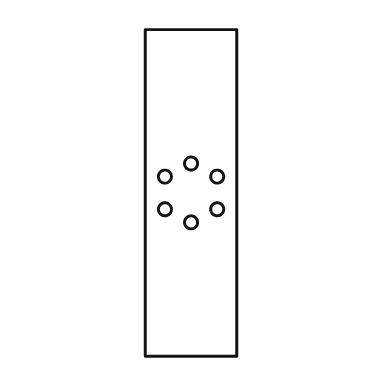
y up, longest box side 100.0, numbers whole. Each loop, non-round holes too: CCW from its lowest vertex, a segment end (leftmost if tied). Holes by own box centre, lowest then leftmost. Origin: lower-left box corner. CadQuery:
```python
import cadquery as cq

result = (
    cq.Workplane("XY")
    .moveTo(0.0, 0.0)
    .lineTo(28.0, 0.0)
    .lineTo(28.0, 100.0)
    .lineTo(0.0, 100.0)
    .close()
    .moveTo(14.0, 41.0)
    .circle(2.0)
    .moveTo(6.0, 45.0)
    .circle(2.0)
    .moveTo(22.0, 45.0)
    .circle(2.0)
    .moveTo(6.0, 55.0)
    .circle(2.0)
    .moveTo(22.0, 55.0)
    .circle(2.0)
    .moveTo(14.0, 59.0)
    .circle(2.0)
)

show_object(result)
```